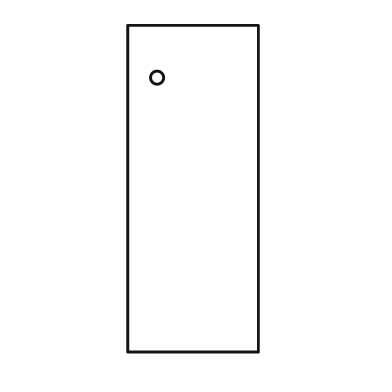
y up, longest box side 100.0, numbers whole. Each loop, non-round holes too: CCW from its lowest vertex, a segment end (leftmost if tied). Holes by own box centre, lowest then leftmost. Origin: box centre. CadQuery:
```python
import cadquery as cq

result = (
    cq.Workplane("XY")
    .moveTo(-20.0, -50.0)
    .lineTo(20.0, -50.0)
    .lineTo(20.0, 50.0)
    .lineTo(-20.0, 50.0)
    .close()
    .moveTo(-11.0, 34.0)
    .circle(2.0)
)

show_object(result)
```